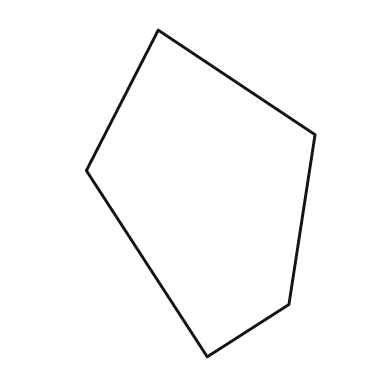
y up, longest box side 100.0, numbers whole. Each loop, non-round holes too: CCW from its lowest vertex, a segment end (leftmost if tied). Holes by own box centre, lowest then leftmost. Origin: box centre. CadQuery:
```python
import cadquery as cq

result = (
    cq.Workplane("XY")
    .moveTo(2.0, -50.0)
    .lineTo(27.0, -34.0)
    .lineTo(35.0, 18.0)
    .lineTo(-13.0, 50.0)
    .lineTo(-35.0, 7.0)
    .close()
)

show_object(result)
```